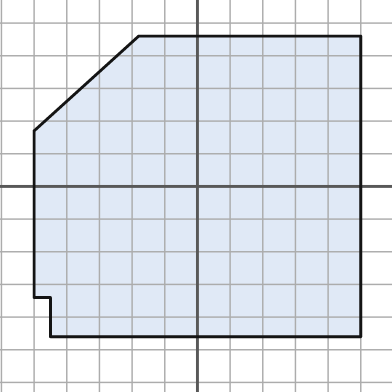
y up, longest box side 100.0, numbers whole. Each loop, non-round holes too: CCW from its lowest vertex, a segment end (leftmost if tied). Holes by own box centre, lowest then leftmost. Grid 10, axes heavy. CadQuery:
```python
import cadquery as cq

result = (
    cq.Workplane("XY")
    .moveTo(-45.0, -46.0)
    .lineTo(50.0, -46.0)
    .lineTo(50.0, 46.0)
    .lineTo(-18.0, 46.0)
    .lineTo(-50.0, 17.0)
    .lineTo(-50.0, -34.0)
    .lineTo(-45.0, -34.0)
    .close()
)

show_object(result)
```